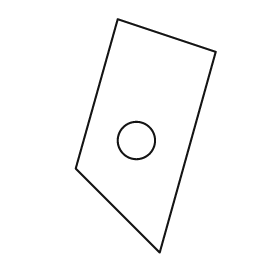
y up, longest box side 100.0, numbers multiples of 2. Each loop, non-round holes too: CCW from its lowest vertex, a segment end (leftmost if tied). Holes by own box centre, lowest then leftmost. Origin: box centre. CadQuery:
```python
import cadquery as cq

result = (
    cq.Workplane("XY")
    .moveTo(6.0, -50.0)
    .lineTo(30.0, 36.0)
    .lineTo(-12.0, 50.0)
    .lineTo(-30.0, -14.0)
    .close()
    .moveTo(-4.0, -2.0)
    .circle(8.0)
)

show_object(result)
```